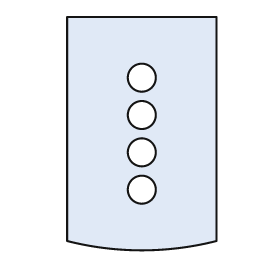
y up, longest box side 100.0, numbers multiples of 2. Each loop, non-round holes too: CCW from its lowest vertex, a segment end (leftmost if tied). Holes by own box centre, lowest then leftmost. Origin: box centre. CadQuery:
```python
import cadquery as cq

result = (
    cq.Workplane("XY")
    .moveTo(-32.0, -46.0)
    .threePointArc((0.0, -50.0), (32.0, -46.0))
    .lineTo(32.0, 50.0)
    .lineTo(-32.0, 50.0)
    .close()
    .moveTo(0.0, -24.0)
    .circle(6.0)
    .moveTo(0.0, -8.0)
    .circle(6.0)
    .moveTo(0.0, 8.0)
    .circle(6.0)
    .moveTo(0.0, 24.0)
    .circle(6.0)
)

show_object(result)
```